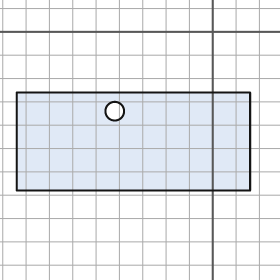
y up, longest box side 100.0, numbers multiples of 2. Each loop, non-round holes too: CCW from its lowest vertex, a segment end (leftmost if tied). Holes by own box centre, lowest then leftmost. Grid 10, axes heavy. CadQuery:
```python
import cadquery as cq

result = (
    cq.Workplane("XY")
    .moveTo(-84.0, -68.0)
    .lineTo(16.0, -68.0)
    .lineTo(16.0, -26.0)
    .lineTo(-84.0, -26.0)
    .close()
    .moveTo(-42.0, -34.0)
    .circle(4.0)
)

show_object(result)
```